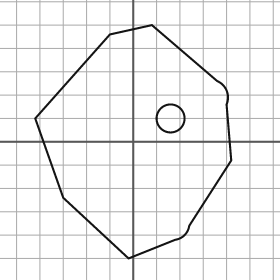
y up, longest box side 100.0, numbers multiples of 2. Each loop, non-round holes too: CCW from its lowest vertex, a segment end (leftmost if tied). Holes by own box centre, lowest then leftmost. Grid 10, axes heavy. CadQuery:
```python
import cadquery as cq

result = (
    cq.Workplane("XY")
    .moveTo(-2.0, -50.0)
    .lineTo(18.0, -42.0)
    .threePointArc((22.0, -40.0), (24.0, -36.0))
    .lineTo(42.0, -8.0)
    .lineTo(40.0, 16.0)
    .threePointArc((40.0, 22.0), (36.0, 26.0))
    .lineTo(8.0, 50.0)
    .lineTo(-10.0, 46.0)
    .lineTo(-42.0, 10.0)
    .lineTo(-30.0, -24.0)
    .close()
    .moveTo(16.0, 10.0)
    .circle(6.0)
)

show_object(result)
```